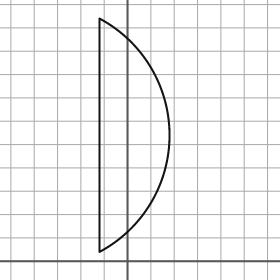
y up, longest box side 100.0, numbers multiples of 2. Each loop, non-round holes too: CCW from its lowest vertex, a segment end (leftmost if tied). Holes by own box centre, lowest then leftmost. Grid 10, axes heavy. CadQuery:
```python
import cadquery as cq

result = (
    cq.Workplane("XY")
    .moveTo(-12.0, 4.0)
    .threePointArc((18.0, 54.0), (-12.0, 104.0))
    .close()
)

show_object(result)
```